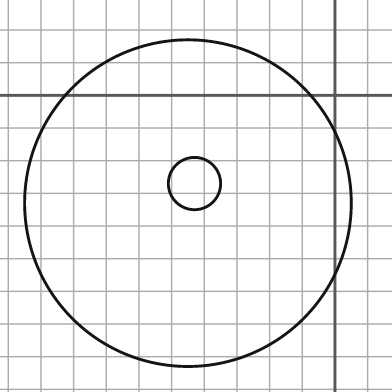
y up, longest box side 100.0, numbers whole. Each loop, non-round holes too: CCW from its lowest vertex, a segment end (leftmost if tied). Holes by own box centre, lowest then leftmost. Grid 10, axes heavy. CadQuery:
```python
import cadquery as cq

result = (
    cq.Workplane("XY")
    .moveTo(-45.0, -33.0)
    .circle(50.0)
    .moveTo(-43.0, -27.0)
    .circle(8.0)
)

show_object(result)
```